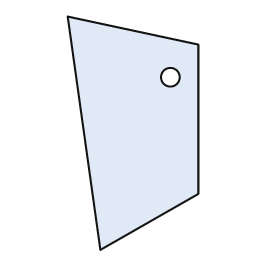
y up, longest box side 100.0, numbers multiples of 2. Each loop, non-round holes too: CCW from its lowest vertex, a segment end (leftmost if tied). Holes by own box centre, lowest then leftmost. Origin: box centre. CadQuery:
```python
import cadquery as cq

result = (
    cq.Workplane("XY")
    .moveTo(-14.0, -50.0)
    .lineTo(28.0, -26.0)
    .lineTo(28.0, 38.0)
    .lineTo(-28.0, 50.0)
    .close()
    .moveTo(16.0, 24.0)
    .circle(4.0)
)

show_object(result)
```